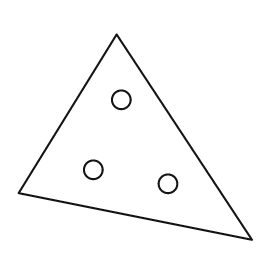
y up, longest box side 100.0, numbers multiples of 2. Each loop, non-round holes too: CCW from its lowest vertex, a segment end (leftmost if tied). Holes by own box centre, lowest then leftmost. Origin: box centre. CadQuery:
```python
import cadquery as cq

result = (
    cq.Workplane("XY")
    .moveTo(50.0, -44.0)
    .lineTo(-8.0, 44.0)
    .lineTo(-50.0, -24.0)
    .close()
    .moveTo(14.0, -20.0)
    .circle(4.0)
    .moveTo(-18.0, -14.0)
    .circle(4.0)
    .moveTo(-6.0, 16.0)
    .circle(4.0)
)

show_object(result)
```